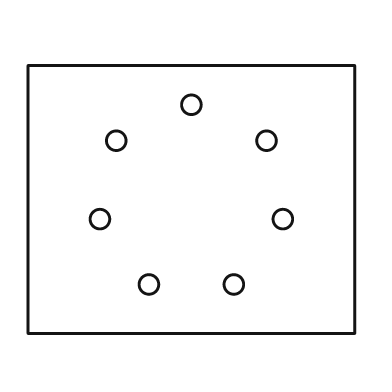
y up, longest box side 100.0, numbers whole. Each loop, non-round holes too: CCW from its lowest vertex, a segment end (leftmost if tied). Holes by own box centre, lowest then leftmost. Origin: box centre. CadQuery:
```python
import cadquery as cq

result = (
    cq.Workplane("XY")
    .moveTo(-50.0, -41.0)
    .lineTo(50.0, -41.0)
    .lineTo(50.0, 41.0)
    .lineTo(-50.0, 41.0)
    .close()
    .moveTo(-13.0, -26.0)
    .circle(3.0)
    .moveTo(13.0, -26.0)
    .circle(3.0)
    .moveTo(-28.0, -6.0)
    .circle(3.0)
    .moveTo(28.0, -6.0)
    .circle(3.0)
    .moveTo(-23.0, 18.0)
    .circle(3.0)
    .moveTo(23.0, 18.0)
    .circle(3.0)
    .moveTo(0.0, 29.0)
    .circle(3.0)
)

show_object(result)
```